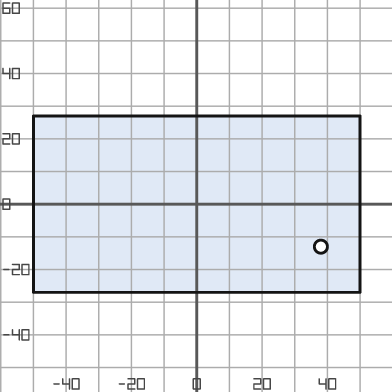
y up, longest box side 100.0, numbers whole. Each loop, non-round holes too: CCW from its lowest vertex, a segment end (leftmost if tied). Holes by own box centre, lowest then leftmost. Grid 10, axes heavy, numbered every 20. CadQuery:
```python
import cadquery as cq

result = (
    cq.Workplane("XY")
    .moveTo(-50.0, -27.0)
    .lineTo(50.0, -27.0)
    .lineTo(50.0, 27.0)
    .lineTo(-50.0, 27.0)
    .close()
    .moveTo(38.0, -13.0)
    .circle(2.0)
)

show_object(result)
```